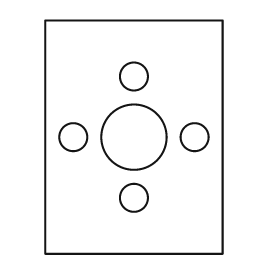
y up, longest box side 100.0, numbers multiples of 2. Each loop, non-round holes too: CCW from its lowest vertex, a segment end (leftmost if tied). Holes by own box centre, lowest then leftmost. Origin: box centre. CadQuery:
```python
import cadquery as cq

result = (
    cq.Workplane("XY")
    .moveTo(-38.0, -50.0)
    .lineTo(38.0, -50.0)
    .lineTo(38.0, 50.0)
    .lineTo(-38.0, 50.0)
    .close()
    .moveTo(0.0, -26.0)
    .circle(6.0)
    .moveTo(-26.0, 0.0)
    .circle(6.0)
    .moveTo(0.0, 0.0)
    .circle(14.0)
    .moveTo(26.0, 0.0)
    .circle(6.0)
    .moveTo(0.0, 26.0)
    .circle(6.0)
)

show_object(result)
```